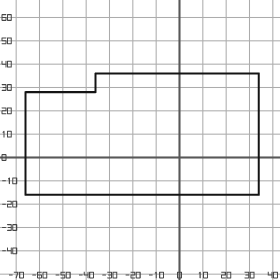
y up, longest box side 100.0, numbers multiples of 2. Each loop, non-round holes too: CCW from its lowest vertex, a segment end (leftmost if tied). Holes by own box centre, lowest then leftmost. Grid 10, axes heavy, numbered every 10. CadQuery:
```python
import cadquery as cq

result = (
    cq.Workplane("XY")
    .moveTo(-66.0, -16.0)
    .lineTo(34.0, -16.0)
    .lineTo(34.0, 36.0)
    .lineTo(-36.0, 36.0)
    .lineTo(-36.0, 28.0)
    .lineTo(-66.0, 28.0)
    .close()
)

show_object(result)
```